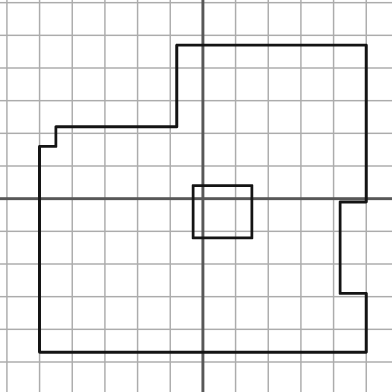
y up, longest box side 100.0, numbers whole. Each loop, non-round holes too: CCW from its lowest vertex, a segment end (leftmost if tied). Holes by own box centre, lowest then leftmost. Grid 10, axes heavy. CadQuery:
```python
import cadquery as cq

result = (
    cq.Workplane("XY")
    .moveTo(-50.0, -47.0)
    .lineTo(50.0, -47.0)
    .lineTo(50.0, -29.0)
    .lineTo(42.0, -29.0)
    .lineTo(42.0, -1.0)
    .lineTo(50.0, -1.0)
    .lineTo(50.0, 47.0)
    .lineTo(-8.0, 47.0)
    .lineTo(-8.0, 22.0)
    .lineTo(-45.0, 22.0)
    .lineTo(-45.0, 16.0)
    .lineTo(-50.0, 16.0)
    .close()
    .moveTo(-3.0, -12.0)
    .lineTo(15.0, -12.0)
    .lineTo(15.0, 4.0)
    .lineTo(-3.0, 4.0)
    .close()
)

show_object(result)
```